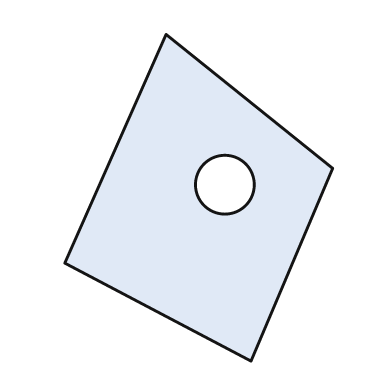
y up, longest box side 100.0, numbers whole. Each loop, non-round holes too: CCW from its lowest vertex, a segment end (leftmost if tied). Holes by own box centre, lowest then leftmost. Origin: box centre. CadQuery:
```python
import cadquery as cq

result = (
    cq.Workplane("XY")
    .moveTo(16.0, -50.0)
    .lineTo(41.0, 9.0)
    .lineTo(-10.0, 50.0)
    .lineTo(-41.0, -20.0)
    .close()
    .moveTo(8.0, 4.0)
    .circle(9.0)
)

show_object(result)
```